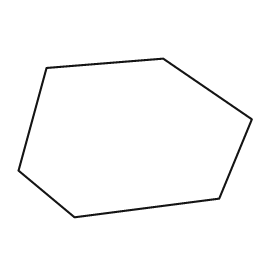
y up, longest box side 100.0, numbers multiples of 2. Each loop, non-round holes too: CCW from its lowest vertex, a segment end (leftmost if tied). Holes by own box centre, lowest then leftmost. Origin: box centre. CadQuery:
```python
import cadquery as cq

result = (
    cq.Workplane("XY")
    .moveTo(-26.0, -34.0)
    .lineTo(36.0, -26.0)
    .lineTo(50.0, 8.0)
    .lineTo(12.0, 34.0)
    .lineTo(-38.0, 30.0)
    .lineTo(-50.0, -14.0)
    .close()
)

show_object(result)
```